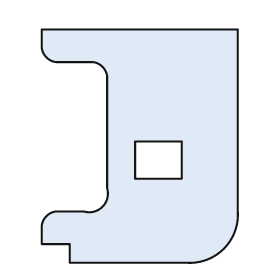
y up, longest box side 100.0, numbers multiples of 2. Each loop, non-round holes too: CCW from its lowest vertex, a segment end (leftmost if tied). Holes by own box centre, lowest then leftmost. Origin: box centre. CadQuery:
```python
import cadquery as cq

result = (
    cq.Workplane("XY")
    .moveTo(-30.0, -50.0)
    .lineTo(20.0, -50.0)
    .threePointArc((36.0, -44.0), (42.0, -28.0))
    .lineTo(42.0, 50.0)
    .lineTo(-42.0, 50.0)
    .lineTo(-42.0, 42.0)
    .threePointArc((-40.0, 38.0), (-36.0, 36.0))
    .lineTo(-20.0, 36.0)
    .threePointArc((-16.0, 34.0), (-14.0, 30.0))
    .lineTo(-14.0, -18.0)
    .threePointArc((-16.0, -26.0), (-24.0, -28.0))
    .lineTo(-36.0, -28.0)
    .threePointArc((-40.0, -30.0), (-42.0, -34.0))
    .lineTo(-42.0, -42.0)
    .lineTo(-30.0, -42.0)
    .close()
    .moveTo(-2.0, -14.0)
    .lineTo(18.0, -14.0)
    .lineTo(18.0, 2.0)
    .lineTo(-2.0, 2.0)
    .close()
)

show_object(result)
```